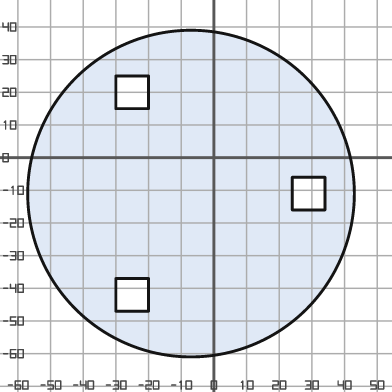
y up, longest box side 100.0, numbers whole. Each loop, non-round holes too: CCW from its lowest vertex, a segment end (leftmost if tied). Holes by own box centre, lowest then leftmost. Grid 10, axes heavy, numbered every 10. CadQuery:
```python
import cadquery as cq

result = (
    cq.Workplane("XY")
    .moveTo(-7.0, -11.0)
    .circle(50.0)
    .moveTo(-30.0, -47.0)
    .lineTo(-20.0, -47.0)
    .lineTo(-20.0, -37.0)
    .lineTo(-30.0, -37.0)
    .close()
    .moveTo(24.0, -16.0)
    .lineTo(34.0, -16.0)
    .lineTo(34.0, -6.0)
    .lineTo(24.0, -6.0)
    .close()
    .moveTo(-30.0, 15.0)
    .lineTo(-20.0, 15.0)
    .lineTo(-20.0, 25.0)
    .lineTo(-30.0, 25.0)
    .close()
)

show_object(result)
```